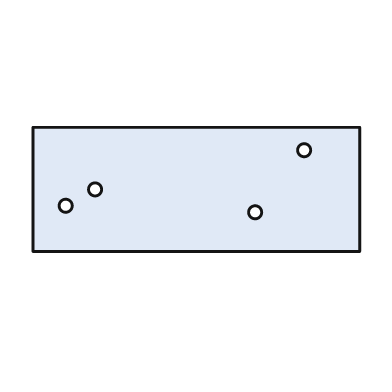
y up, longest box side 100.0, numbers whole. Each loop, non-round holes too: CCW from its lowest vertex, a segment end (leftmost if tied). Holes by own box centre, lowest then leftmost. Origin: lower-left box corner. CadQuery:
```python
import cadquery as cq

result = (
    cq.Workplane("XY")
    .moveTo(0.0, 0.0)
    .lineTo(100.0, 0.0)
    .lineTo(100.0, 38.0)
    .lineTo(0.0, 38.0)
    .close()
    .moveTo(68.0, 12.0)
    .circle(2.0)
    .moveTo(10.0, 14.0)
    .circle(2.0)
    .moveTo(19.0, 19.0)
    .circle(2.0)
    .moveTo(83.0, 31.0)
    .circle(2.0)
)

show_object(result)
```